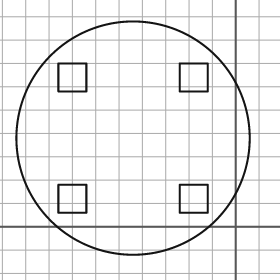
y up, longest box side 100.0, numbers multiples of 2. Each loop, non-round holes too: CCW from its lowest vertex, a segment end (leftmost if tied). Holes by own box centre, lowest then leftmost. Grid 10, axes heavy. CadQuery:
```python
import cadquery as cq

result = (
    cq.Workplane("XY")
    .moveTo(-44.0, 38.0)
    .circle(50.0)
    .moveTo(-76.0, 6.0)
    .lineTo(-64.0, 6.0)
    .lineTo(-64.0, 18.0)
    .lineTo(-76.0, 18.0)
    .close()
    .moveTo(-24.0, 6.0)
    .lineTo(-12.0, 6.0)
    .lineTo(-12.0, 18.0)
    .lineTo(-24.0, 18.0)
    .close()
    .moveTo(-76.0, 58.0)
    .lineTo(-64.0, 58.0)
    .lineTo(-64.0, 70.0)
    .lineTo(-76.0, 70.0)
    .close()
    .moveTo(-24.0, 58.0)
    .lineTo(-12.0, 58.0)
    .lineTo(-12.0, 70.0)
    .lineTo(-24.0, 70.0)
    .close()
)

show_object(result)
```